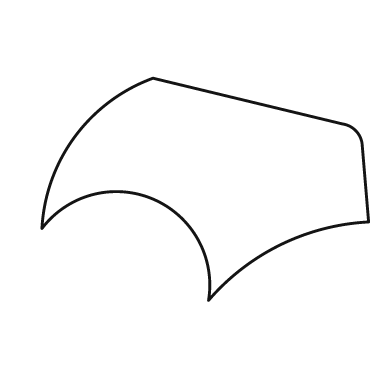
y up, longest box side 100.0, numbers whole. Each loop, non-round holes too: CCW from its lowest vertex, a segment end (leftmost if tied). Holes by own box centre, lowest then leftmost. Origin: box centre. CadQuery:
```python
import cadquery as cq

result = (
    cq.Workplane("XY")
    .moveTo(1.0, -34.0)
    .threePointArc((23.0, -17.0), (50.0, -10.0))
    .lineTo(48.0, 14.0)
    .threePointArc((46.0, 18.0), (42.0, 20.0))
    .lineTo(-16.0, 34.0)
    .threePointArc((-40.0, 16.0), (-50.0, -12.0))
    .threePointArc((-16.0, -3.0), (1.0, -34.0))
    .close()
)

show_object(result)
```